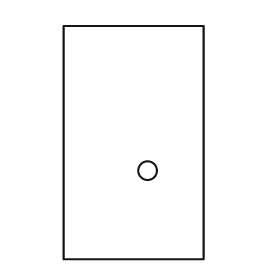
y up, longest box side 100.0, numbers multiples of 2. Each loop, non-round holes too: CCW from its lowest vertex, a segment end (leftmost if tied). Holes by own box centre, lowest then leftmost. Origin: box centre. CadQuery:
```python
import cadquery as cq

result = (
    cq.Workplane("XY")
    .moveTo(-30.0, -50.0)
    .lineTo(30.0, -50.0)
    .lineTo(30.0, 50.0)
    .lineTo(-30.0, 50.0)
    .close()
    .moveTo(6.0, -12.0)
    .circle(4.0)
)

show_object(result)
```